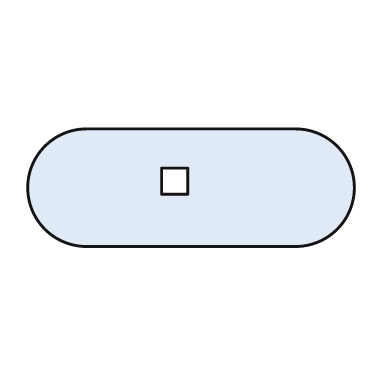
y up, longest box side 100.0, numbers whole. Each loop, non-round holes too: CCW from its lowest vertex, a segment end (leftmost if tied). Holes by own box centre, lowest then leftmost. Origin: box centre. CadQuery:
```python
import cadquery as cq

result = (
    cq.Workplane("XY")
    .moveTo(-32.0, -18.0)
    .lineTo(32.0, -18.0)
    .threePointArc((50.0, 0.0), (32.0, 18.0))
    .lineTo(-32.0, 18.0)
    .threePointArc((-50.0, 0.0), (-32.0, -18.0))
    .close()
    .moveTo(-9.0, -2.0)
    .lineTo(-1.0, -2.0)
    .lineTo(-1.0, 6.0)
    .lineTo(-9.0, 6.0)
    .close()
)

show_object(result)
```